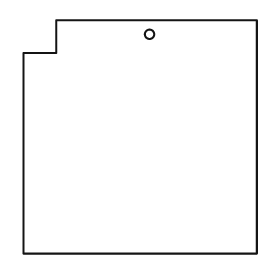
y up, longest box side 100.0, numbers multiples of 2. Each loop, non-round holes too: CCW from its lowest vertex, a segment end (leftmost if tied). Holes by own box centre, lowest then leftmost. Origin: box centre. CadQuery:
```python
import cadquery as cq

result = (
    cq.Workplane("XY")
    .moveTo(-50.0, -50.0)
    .lineTo(50.0, -50.0)
    .lineTo(50.0, 50.0)
    .lineTo(-36.0, 50.0)
    .lineTo(-36.0, 36.0)
    .lineTo(-50.0, 36.0)
    .close()
    .moveTo(4.0, 44.0)
    .circle(2.0)
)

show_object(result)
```